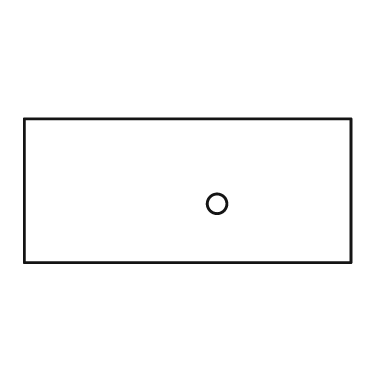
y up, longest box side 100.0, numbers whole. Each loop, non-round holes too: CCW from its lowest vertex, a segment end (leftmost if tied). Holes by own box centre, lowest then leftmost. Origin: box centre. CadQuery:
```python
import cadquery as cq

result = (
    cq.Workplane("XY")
    .moveTo(-50.0, -22.0)
    .lineTo(50.0, -22.0)
    .lineTo(50.0, 22.0)
    .lineTo(-50.0, 22.0)
    .close()
    .moveTo(9.0, -4.0)
    .circle(3.0)
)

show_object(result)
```